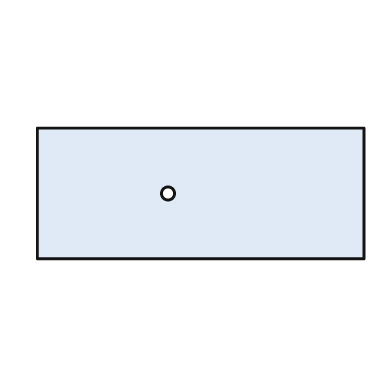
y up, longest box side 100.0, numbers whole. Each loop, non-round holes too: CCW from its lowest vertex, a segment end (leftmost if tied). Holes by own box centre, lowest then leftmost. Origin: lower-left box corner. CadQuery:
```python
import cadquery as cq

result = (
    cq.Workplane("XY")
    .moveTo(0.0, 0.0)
    .lineTo(100.0, 0.0)
    .lineTo(100.0, 40.0)
    .lineTo(0.0, 40.0)
    .close()
    .moveTo(40.0, 20.0)
    .circle(2.0)
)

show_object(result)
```